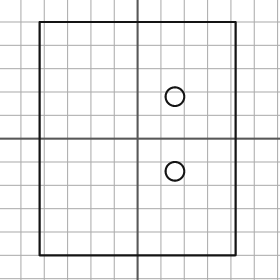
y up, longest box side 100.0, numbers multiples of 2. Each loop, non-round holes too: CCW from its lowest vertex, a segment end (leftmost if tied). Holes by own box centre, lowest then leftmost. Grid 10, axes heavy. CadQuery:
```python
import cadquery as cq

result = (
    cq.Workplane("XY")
    .moveTo(-42.0, -50.0)
    .lineTo(42.0, -50.0)
    .lineTo(42.0, 50.0)
    .lineTo(-42.0, 50.0)
    .close()
    .moveTo(16.0, -14.0)
    .circle(4.0)
    .moveTo(16.0, 18.0)
    .circle(4.0)
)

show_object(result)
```